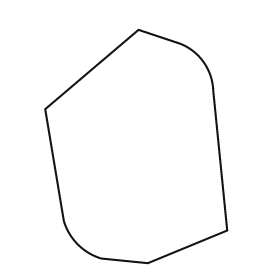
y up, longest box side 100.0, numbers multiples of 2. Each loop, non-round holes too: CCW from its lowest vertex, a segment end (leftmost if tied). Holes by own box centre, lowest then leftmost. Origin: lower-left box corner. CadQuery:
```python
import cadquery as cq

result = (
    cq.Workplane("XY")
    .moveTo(44.0, 0.0)
    .lineTo(78.0, 14.0)
    .lineTo(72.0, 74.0)
    .threePointArc((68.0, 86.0), (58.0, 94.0))
    .lineTo(40.0, 100.0)
    .lineTo(0.0, 66.0)
    .lineTo(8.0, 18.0)
    .threePointArc((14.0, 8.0), (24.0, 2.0))
    .close()
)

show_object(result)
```